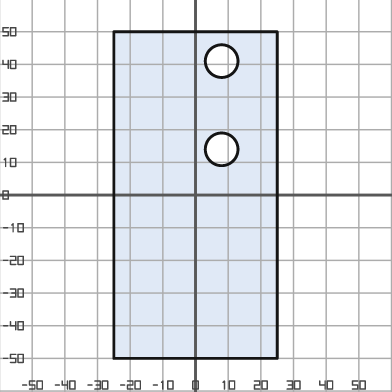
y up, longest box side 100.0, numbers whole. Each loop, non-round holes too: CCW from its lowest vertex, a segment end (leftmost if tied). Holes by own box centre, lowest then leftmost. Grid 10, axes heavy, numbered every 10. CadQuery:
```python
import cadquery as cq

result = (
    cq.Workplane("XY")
    .moveTo(-25.0, -50.0)
    .lineTo(25.0, -50.0)
    .lineTo(25.0, 50.0)
    .lineTo(-25.0, 50.0)
    .close()
    .moveTo(8.0, 14.0)
    .circle(5.0)
    .moveTo(8.0, 41.0)
    .circle(5.0)
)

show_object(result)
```